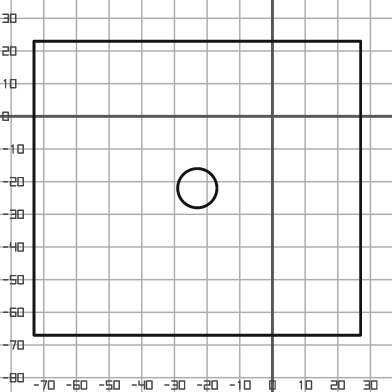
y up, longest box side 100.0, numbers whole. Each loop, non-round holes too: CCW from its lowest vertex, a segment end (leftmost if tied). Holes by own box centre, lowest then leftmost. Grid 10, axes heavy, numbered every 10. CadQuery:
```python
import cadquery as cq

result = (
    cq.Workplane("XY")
    .moveTo(-73.0, -67.0)
    .lineTo(27.0, -67.0)
    .lineTo(27.0, 23.0)
    .lineTo(-73.0, 23.0)
    .close()
    .moveTo(-23.0, -22.0)
    .circle(6.0)
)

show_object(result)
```